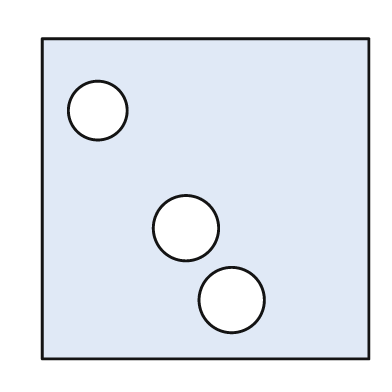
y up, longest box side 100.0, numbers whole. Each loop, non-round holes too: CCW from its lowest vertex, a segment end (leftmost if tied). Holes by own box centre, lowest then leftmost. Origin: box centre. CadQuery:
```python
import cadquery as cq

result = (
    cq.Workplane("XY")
    .moveTo(-50.0, -49.0)
    .lineTo(50.0, -49.0)
    .lineTo(50.0, 49.0)
    .lineTo(-50.0, 49.0)
    .close()
    .moveTo(8.0, -31.0)
    .circle(10.0)
    .moveTo(-6.0, -9.0)
    .circle(10.0)
    .moveTo(-33.0, 27.0)
    .circle(9.0)
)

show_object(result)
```